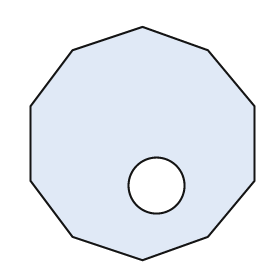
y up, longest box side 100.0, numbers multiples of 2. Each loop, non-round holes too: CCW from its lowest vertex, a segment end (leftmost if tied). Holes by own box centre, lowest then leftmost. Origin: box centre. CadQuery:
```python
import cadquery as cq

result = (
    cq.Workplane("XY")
    .moveTo(0.0, -50.0)
    .lineTo(28.0, -40.0)
    .lineTo(48.0, -16.0)
    .lineTo(48.0, 16.0)
    .lineTo(28.0, 40.0)
    .lineTo(0.0, 50.0)
    .lineTo(-30.0, 40.0)
    .lineTo(-48.0, 16.0)
    .lineTo(-48.0, -16.0)
    .lineTo(-30.0, -40.0)
    .close()
    .moveTo(6.0, -18.0)
    .circle(12.0)
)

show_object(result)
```